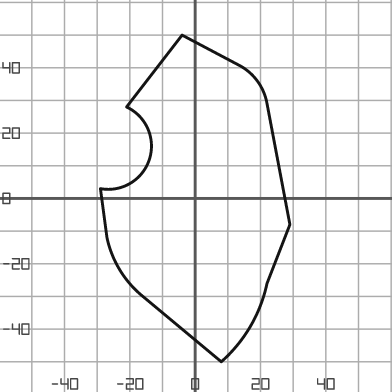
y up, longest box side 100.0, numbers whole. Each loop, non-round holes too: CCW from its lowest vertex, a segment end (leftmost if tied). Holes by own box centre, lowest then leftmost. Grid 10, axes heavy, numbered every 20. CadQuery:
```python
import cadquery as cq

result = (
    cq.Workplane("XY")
    .moveTo(8.0, -50.0)
    .threePointArc((17.0, -39.0), (22.0, -26.0))
    .lineTo(29.0, -8.0)
    .lineTo(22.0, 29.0)
    .threePointArc((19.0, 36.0), (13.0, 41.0))
    .lineTo(-4.0, 50.0)
    .lineTo(-21.0, 28.0)
    .threePointArc((-14.0, 12.0), (-29.0, 3.0))
    .lineTo(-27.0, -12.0)
    .threePointArc((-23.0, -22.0), (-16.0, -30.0))
    .close()
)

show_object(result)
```